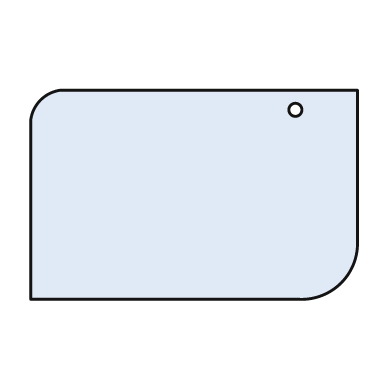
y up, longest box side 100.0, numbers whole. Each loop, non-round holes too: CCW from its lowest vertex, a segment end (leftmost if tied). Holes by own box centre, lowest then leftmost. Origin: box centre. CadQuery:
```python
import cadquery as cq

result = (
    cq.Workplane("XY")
    .moveTo(-50.0, -32.0)
    .lineTo(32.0, -32.0)
    .threePointArc((45.0, -27.0), (50.0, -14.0))
    .lineTo(50.0, 32.0)
    .lineTo(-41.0, 32.0)
    .threePointArc((-47.0, 29.0), (-50.0, 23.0))
    .close()
    .moveTo(31.0, 26.0)
    .circle(2.0)
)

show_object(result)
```